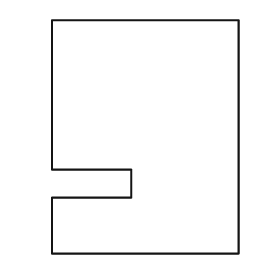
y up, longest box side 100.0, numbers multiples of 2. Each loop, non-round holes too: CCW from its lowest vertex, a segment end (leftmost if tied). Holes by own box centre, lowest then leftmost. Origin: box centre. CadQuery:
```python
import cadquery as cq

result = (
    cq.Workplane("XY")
    .moveTo(-40.0, -50.0)
    .lineTo(40.0, -50.0)
    .lineTo(40.0, 50.0)
    .lineTo(-40.0, 50.0)
    .lineTo(-40.0, -14.0)
    .lineTo(-6.0, -14.0)
    .lineTo(-6.0, -26.0)
    .lineTo(-40.0, -26.0)
    .close()
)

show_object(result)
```